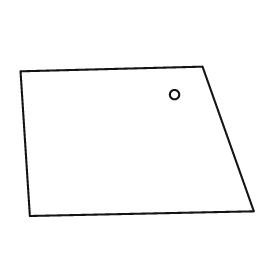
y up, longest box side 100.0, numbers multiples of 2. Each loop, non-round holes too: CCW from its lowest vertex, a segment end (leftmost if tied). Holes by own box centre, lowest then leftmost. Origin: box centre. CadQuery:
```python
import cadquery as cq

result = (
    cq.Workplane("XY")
    .moveTo(-46.0, -32.0)
    .lineTo(50.0, -30.0)
    .lineTo(28.0, 32.0)
    .lineTo(-50.0, 30.0)
    .close()
    .moveTo(16.0, 20.0)
    .circle(2.0)
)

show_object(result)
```